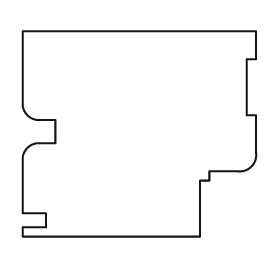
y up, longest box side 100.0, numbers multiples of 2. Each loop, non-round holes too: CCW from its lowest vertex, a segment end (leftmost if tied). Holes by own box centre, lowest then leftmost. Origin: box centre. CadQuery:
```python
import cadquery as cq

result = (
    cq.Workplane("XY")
    .moveTo(-50.0, -44.0)
    .lineTo(26.0, -44.0)
    .lineTo(26.0, -20.0)
    .lineTo(30.0, -20.0)
    .lineTo(30.0, -16.0)
    .lineTo(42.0, -16.0)
    .threePointArc((48.0, -14.0), (50.0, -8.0))
    .lineTo(50.0, 8.0)
    .lineTo(46.0, 8.0)
    .lineTo(46.0, 32.0)
    .lineTo(50.0, 32.0)
    .lineTo(50.0, 44.0)
    .lineTo(-50.0, 44.0)
    .lineTo(-50.0, 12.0)
    .threePointArc((-48.0, 8.0), (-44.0, 6.0))
    .lineTo(-36.0, 6.0)
    .lineTo(-36.0, -4.0)
    .lineTo(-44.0, -4.0)
    .threePointArc((-48.0, -6.0), (-50.0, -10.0))
    .lineTo(-50.0, -34.0)
    .lineTo(-40.0, -34.0)
    .lineTo(-40.0, -40.0)
    .lineTo(-50.0, -40.0)
    .close()
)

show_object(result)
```